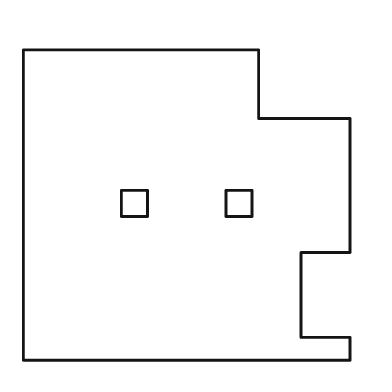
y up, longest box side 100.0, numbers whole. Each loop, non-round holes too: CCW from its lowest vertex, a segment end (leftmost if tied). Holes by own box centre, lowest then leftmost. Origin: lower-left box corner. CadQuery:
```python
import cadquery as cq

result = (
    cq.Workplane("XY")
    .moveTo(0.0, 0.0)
    .lineTo(100.0, 0.0)
    .lineTo(100.0, 7.0)
    .lineTo(85.0, 7.0)
    .lineTo(85.0, 33.0)
    .lineTo(100.0, 33.0)
    .lineTo(100.0, 74.0)
    .lineTo(72.0, 74.0)
    .lineTo(72.0, 95.0)
    .lineTo(0.0, 95.0)
    .close()
    .moveTo(30.0, 44.0)
    .lineTo(38.0, 44.0)
    .lineTo(38.0, 52.0)
    .lineTo(30.0, 52.0)
    .close()
    .moveTo(62.0, 44.0)
    .lineTo(70.0, 44.0)
    .lineTo(70.0, 52.0)
    .lineTo(62.0, 52.0)
    .close()
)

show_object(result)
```